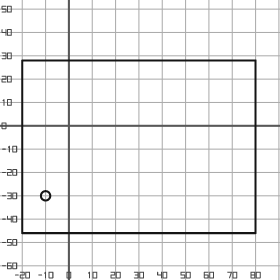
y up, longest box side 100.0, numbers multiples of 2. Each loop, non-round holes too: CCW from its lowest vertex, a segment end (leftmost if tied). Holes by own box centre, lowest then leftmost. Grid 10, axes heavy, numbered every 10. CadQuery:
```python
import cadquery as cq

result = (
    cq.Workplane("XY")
    .moveTo(-20.0, -46.0)
    .lineTo(80.0, -46.0)
    .lineTo(80.0, 28.0)
    .lineTo(-20.0, 28.0)
    .close()
    .moveTo(-10.0, -30.0)
    .circle(2.0)
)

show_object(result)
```